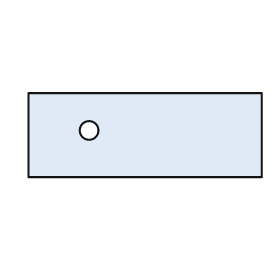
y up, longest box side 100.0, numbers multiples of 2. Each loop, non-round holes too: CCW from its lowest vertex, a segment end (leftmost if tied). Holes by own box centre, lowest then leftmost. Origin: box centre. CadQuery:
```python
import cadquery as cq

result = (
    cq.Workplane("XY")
    .moveTo(-50.0, -18.0)
    .lineTo(50.0, -18.0)
    .lineTo(50.0, 18.0)
    .lineTo(-50.0, 18.0)
    .close()
    .moveTo(-24.0, 2.0)
    .circle(4.0)
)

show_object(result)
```